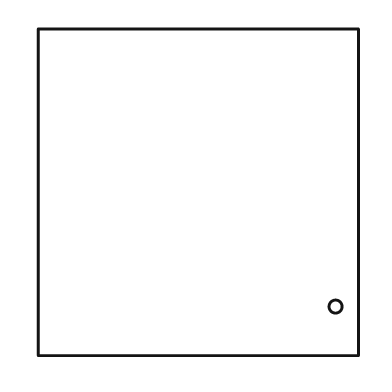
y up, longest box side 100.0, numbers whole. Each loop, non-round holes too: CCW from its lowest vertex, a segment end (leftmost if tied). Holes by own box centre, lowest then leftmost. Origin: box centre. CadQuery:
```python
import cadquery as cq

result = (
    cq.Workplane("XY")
    .moveTo(-49.0, -50.0)
    .lineTo(49.0, -50.0)
    .lineTo(49.0, 50.0)
    .lineTo(-49.0, 50.0)
    .close()
    .moveTo(42.0, -35.0)
    .circle(2.0)
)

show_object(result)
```